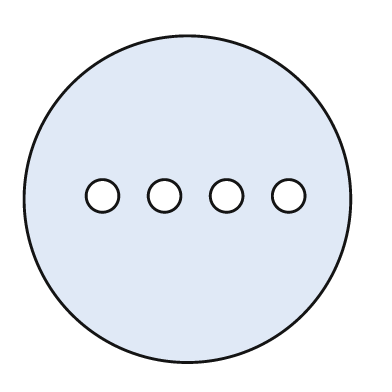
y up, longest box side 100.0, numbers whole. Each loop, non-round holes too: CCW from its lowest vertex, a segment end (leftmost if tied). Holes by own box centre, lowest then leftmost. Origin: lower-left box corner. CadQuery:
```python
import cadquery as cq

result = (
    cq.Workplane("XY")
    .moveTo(50.0, 50.0)
    .circle(50.0)
    .moveTo(24.0, 51.0)
    .circle(5.0)
    .moveTo(43.0, 51.0)
    .circle(5.0)
    .moveTo(62.0, 51.0)
    .circle(5.0)
    .moveTo(81.0, 51.0)
    .circle(5.0)
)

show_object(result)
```